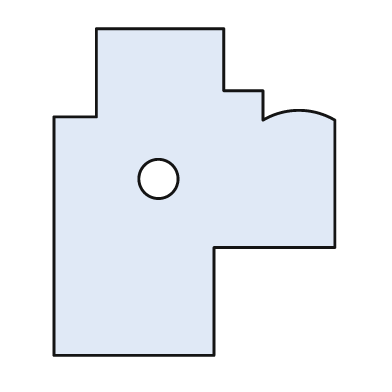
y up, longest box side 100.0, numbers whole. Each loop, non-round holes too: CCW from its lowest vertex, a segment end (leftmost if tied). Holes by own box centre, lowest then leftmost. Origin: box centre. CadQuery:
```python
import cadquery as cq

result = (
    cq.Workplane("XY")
    .moveTo(-43.0, -50.0)
    .lineTo(6.0, -50.0)
    .lineTo(6.0, -17.0)
    .lineTo(43.0, -17.0)
    .lineTo(43.0, 22.0)
    .threePointArc((32.0, 25.0), (21.0, 22.0))
    .lineTo(21.0, 31.0)
    .lineTo(9.0, 31.0)
    .lineTo(9.0, 50.0)
    .lineTo(-30.0, 50.0)
    .lineTo(-30.0, 23.0)
    .lineTo(-43.0, 23.0)
    .close()
    .moveTo(-11.0, 4.0)
    .circle(6.0)
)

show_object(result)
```